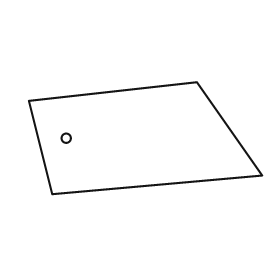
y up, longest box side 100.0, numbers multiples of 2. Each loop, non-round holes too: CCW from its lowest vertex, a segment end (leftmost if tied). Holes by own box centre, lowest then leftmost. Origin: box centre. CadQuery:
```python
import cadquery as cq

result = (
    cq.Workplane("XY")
    .moveTo(-40.0, -24.0)
    .lineTo(50.0, -16.0)
    .lineTo(22.0, 24.0)
    .lineTo(-50.0, 16.0)
    .close()
    .moveTo(-34.0, 0.0)
    .circle(2.0)
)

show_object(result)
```